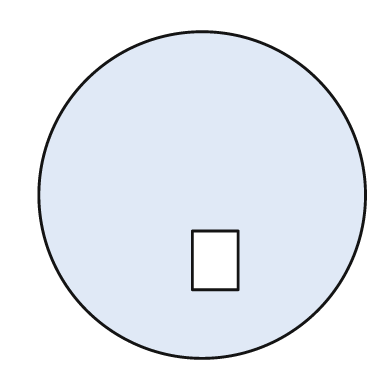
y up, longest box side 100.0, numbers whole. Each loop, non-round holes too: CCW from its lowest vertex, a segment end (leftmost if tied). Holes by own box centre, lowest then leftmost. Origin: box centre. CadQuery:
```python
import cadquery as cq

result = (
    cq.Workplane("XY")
    .moveTo(0.0, 0.0)
    .circle(50.0)
    .moveTo(-3.0, -29.0)
    .lineTo(11.0, -29.0)
    .lineTo(11.0, -11.0)
    .lineTo(-3.0, -11.0)
    .close()
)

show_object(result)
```